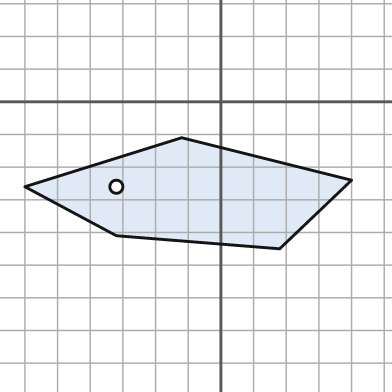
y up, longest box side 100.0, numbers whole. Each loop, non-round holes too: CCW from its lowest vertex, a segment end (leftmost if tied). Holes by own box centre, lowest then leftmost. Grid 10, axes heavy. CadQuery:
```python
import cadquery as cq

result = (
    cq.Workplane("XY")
    .moveTo(18.0, -45.0)
    .lineTo(40.0, -24.0)
    .lineTo(-12.0, -11.0)
    .lineTo(-60.0, -26.0)
    .lineTo(-32.0, -41.0)
    .close()
    .moveTo(-32.0, -26.0)
    .circle(2.0)
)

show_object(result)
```